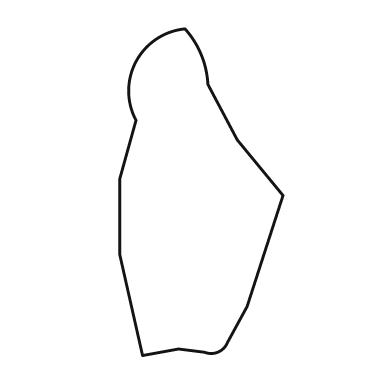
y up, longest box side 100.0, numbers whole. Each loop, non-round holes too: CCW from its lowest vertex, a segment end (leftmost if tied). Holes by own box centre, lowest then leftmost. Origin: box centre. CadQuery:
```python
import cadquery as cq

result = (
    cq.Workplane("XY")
    .moveTo(-18.0, -50.0)
    .lineTo(-7.0, -48.0)
    .lineTo(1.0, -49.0)
    .threePointArc((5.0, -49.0), (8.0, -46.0))
    .lineTo(14.0, -35.0)
    .lineTo(25.0, -1.0)
    .lineTo(11.0, 16.0)
    .lineTo(2.0, 33.0)
    .threePointArc((0.0, 42.0), (-5.0, 50.0))
    .threePointArc((-20.0, 40.0), (-20.0, 22.0))
    .lineTo(-25.0, 4.0)
    .lineTo(-25.0, -19.0)
    .close()
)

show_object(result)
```